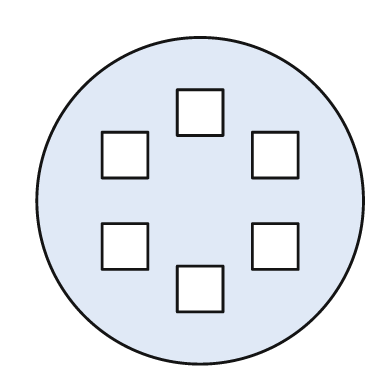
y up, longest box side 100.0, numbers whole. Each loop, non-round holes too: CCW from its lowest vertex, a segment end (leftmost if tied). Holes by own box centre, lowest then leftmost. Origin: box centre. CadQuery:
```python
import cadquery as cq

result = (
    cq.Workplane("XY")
    .moveTo(0.0, 0.0)
    .circle(50.0)
    .moveTo(-7.0, -34.0)
    .lineTo(7.0, -34.0)
    .lineTo(7.0, -20.0)
    .lineTo(-7.0, -20.0)
    .close()
    .moveTo(-30.0, -21.0)
    .lineTo(-16.0, -21.0)
    .lineTo(-16.0, -7.0)
    .lineTo(-30.0, -7.0)
    .close()
    .moveTo(16.0, -21.0)
    .lineTo(30.0, -21.0)
    .lineTo(30.0, -7.0)
    .lineTo(16.0, -7.0)
    .close()
    .moveTo(-30.0, 7.0)
    .lineTo(-16.0, 7.0)
    .lineTo(-16.0, 21.0)
    .lineTo(-30.0, 21.0)
    .close()
    .moveTo(16.0, 7.0)
    .lineTo(30.0, 7.0)
    .lineTo(30.0, 21.0)
    .lineTo(16.0, 21.0)
    .close()
    .moveTo(-7.0, 20.0)
    .lineTo(7.0, 20.0)
    .lineTo(7.0, 34.0)
    .lineTo(-7.0, 34.0)
    .close()
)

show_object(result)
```